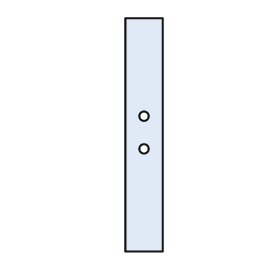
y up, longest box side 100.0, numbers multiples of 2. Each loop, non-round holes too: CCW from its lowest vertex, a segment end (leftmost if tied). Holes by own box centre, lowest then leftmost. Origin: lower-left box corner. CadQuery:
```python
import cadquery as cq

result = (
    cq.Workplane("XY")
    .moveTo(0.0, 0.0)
    .lineTo(16.0, 0.0)
    .lineTo(16.0, 100.0)
    .lineTo(0.0, 100.0)
    .close()
    .moveTo(8.0, 44.0)
    .circle(2.0)
    .moveTo(8.0, 58.0)
    .circle(2.0)
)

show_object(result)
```